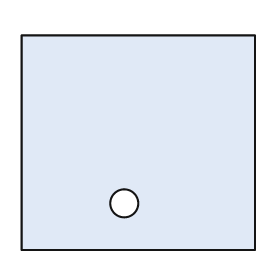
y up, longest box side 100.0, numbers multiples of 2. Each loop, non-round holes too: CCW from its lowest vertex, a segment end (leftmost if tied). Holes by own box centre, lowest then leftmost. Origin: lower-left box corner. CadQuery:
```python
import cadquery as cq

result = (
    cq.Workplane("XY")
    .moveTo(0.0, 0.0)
    .lineTo(100.0, 0.0)
    .lineTo(100.0, 92.0)
    .lineTo(0.0, 92.0)
    .close()
    .moveTo(44.0, 20.0)
    .circle(6.0)
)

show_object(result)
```